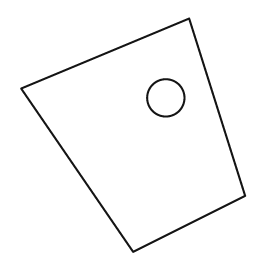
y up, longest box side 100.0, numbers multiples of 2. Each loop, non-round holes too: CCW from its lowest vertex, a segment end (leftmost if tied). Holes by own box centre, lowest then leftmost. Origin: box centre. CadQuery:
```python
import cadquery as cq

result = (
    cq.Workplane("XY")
    .moveTo(0.0, -50.0)
    .lineTo(48.0, -26.0)
    .lineTo(24.0, 50.0)
    .lineTo(-48.0, 20.0)
    .close()
    .moveTo(14.0, 16.0)
    .circle(8.0)
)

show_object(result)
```